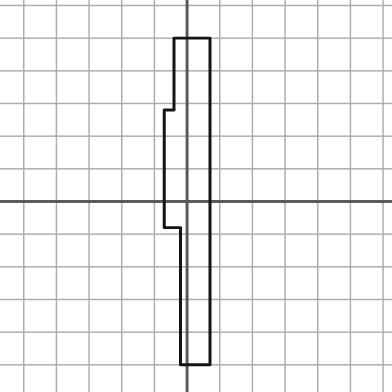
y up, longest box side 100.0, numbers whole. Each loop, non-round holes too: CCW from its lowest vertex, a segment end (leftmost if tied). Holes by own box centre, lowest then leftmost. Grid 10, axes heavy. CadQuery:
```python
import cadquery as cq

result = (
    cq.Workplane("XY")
    .moveTo(-2.0, -50.0)
    .lineTo(7.0, -50.0)
    .lineTo(7.0, 50.0)
    .lineTo(-4.0, 50.0)
    .lineTo(-4.0, 28.0)
    .lineTo(-7.0, 28.0)
    .lineTo(-7.0, -8.0)
    .lineTo(-2.0, -8.0)
    .close()
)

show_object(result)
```